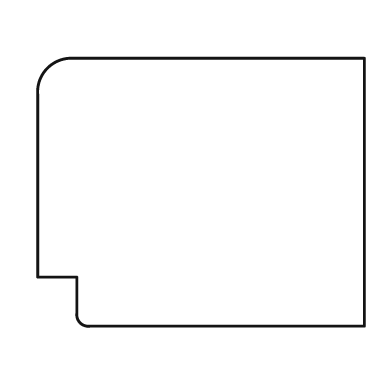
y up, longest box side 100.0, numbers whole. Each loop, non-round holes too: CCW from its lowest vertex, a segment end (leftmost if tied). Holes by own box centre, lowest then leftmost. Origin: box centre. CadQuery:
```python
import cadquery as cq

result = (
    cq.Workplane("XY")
    .moveTo(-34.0, -41.0)
    .lineTo(50.0, -41.0)
    .lineTo(50.0, 41.0)
    .lineTo(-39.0, 41.0)
    .threePointArc((-47.0, 38.0), (-50.0, 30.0))
    .lineTo(-50.0, -26.0)
    .lineTo(-38.0, -26.0)
    .lineTo(-38.0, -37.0)
    .threePointArc((-37.0, -40.0), (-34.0, -41.0))
    .close()
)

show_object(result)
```